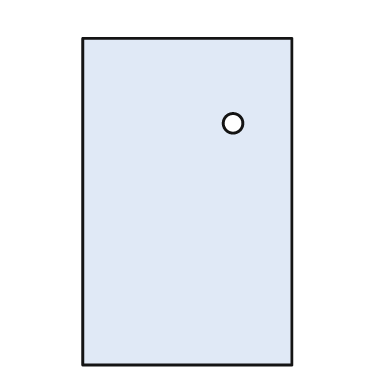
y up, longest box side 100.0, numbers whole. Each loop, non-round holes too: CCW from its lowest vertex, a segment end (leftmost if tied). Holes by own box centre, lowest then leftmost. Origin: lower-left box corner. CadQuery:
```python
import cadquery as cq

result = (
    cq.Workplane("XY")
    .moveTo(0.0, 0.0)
    .lineTo(64.0, 0.0)
    .lineTo(64.0, 100.0)
    .lineTo(0.0, 100.0)
    .close()
    .moveTo(46.0, 74.0)
    .circle(3.0)
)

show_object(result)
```